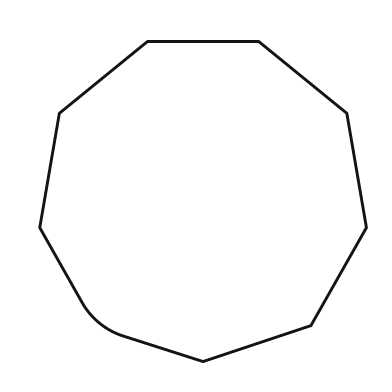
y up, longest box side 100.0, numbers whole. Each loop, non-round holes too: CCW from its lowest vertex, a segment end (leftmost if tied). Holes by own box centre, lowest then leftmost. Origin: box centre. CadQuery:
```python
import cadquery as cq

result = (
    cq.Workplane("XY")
    .moveTo(0.0, -49.0)
    .lineTo(33.0, -38.0)
    .lineTo(50.0, -8.0)
    .lineTo(44.0, 27.0)
    .lineTo(17.0, 49.0)
    .lineTo(-17.0, 49.0)
    .lineTo(-44.0, 27.0)
    .lineTo(-50.0, -8.0)
    .lineTo(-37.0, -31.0)
    .threePointArc((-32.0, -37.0), (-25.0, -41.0))
    .close()
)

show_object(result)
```